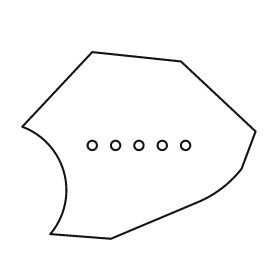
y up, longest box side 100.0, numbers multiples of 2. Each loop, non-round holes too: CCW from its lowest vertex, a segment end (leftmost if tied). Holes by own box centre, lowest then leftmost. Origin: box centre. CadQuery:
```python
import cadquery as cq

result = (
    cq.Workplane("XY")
    .moveTo(-12.0, -40.0)
    .lineTo(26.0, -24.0)
    .threePointArc((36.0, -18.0), (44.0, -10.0))
    .lineTo(50.0, 6.0)
    .lineTo(18.0, 36.0)
    .lineTo(-20.0, 40.0)
    .lineTo(-50.0, 8.0)
    .threePointArc((-32.0, -12.0), (-38.0, -38.0))
    .close()
    .moveTo(-20.0, 0.0)
    .circle(2.0)
    .moveTo(-10.0, 0.0)
    .circle(2.0)
    .moveTo(0.0, 0.0)
    .circle(2.0)
    .moveTo(10.0, 0.0)
    .circle(2.0)
    .moveTo(20.0, 0.0)
    .circle(2.0)
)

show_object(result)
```